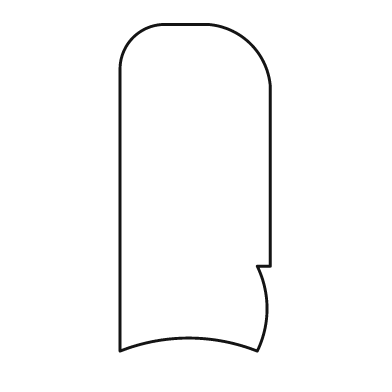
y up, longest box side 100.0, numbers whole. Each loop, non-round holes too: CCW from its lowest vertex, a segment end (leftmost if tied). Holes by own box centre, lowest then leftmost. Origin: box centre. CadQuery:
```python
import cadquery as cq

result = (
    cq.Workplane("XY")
    .moveTo(-23.0, -50.0)
    .threePointArc((-2.0, -46.0), (19.0, -50.0))
    .threePointArc((22.0, -37.0), (19.0, -24.0))
    .lineTo(23.0, -24.0)
    .lineTo(23.0, 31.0)
    .threePointArc((17.0, 44.0), (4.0, 50.0))
    .lineTo(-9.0, 50.0)
    .threePointArc((-19.0, 46.0), (-23.0, 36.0))
    .close()
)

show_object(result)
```